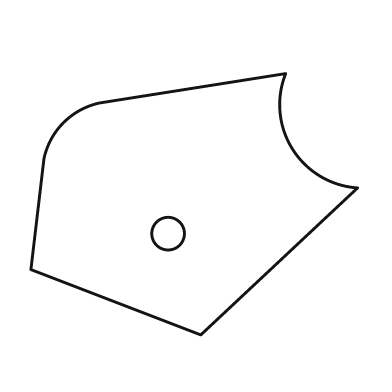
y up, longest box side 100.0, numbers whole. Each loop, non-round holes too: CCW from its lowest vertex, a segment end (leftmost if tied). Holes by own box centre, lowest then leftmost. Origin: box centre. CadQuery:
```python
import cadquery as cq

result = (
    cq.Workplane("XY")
    .moveTo(2.0, -40.0)
    .lineTo(50.0, 5.0)
    .threePointArc((30.0, 17.0), (28.0, 40.0))
    .lineTo(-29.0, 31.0)
    .threePointArc((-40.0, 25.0), (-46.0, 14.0))
    .lineTo(-50.0, -20.0)
    .close()
    .moveTo(-8.0, -9.0)
    .circle(5.0)
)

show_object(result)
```